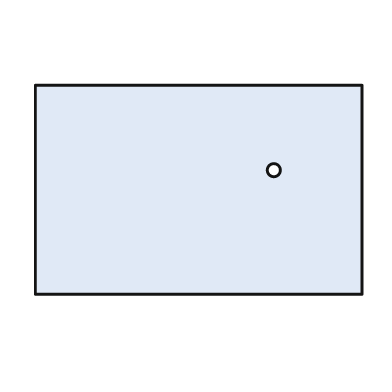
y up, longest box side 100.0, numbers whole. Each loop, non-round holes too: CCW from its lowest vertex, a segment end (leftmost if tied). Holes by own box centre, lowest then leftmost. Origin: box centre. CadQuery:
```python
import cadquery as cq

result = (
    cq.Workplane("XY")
    .moveTo(-50.0, -32.0)
    .lineTo(50.0, -32.0)
    .lineTo(50.0, 32.0)
    .lineTo(-50.0, 32.0)
    .close()
    .moveTo(23.0, 6.0)
    .circle(2.0)
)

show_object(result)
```